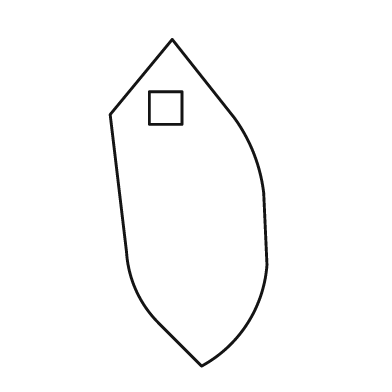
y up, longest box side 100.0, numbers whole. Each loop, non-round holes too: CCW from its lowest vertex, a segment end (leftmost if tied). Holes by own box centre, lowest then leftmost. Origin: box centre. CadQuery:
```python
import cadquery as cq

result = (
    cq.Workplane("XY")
    .moveTo(4.0, -50.0)
    .threePointArc((18.0, -37.0), (24.0, -19.0))
    .lineTo(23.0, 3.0)
    .threePointArc((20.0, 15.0), (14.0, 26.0))
    .lineTo(-5.0, 50.0)
    .lineTo(-24.0, 27.0)
    .lineTo(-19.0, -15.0)
    .threePointArc((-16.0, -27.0), (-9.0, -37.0))
    .close()
    .moveTo(-12.0, 24.0)
    .lineTo(-2.0, 24.0)
    .lineTo(-2.0, 34.0)
    .lineTo(-12.0, 34.0)
    .close()
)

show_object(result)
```